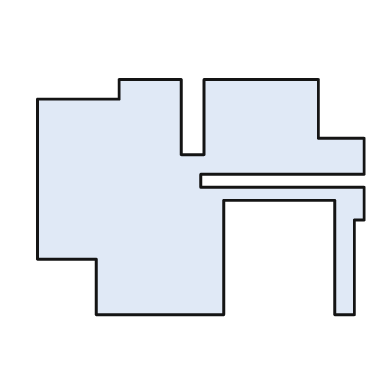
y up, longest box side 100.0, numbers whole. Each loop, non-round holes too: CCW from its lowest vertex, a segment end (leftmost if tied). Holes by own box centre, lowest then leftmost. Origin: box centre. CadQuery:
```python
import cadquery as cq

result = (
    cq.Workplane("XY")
    .moveTo(-32.0, -36.0)
    .lineTo(7.0, -36.0)
    .lineTo(7.0, -1.0)
    .lineTo(41.0, -1.0)
    .lineTo(41.0, -36.0)
    .lineTo(47.0, -36.0)
    .lineTo(47.0, -7.0)
    .lineTo(50.0, -7.0)
    .lineTo(50.0, 3.0)
    .lineTo(0.0, 3.0)
    .lineTo(0.0, 7.0)
    .lineTo(50.0, 7.0)
    .lineTo(50.0, 18.0)
    .lineTo(36.0, 18.0)
    .lineTo(36.0, 36.0)
    .lineTo(1.0, 36.0)
    .lineTo(1.0, 13.0)
    .lineTo(-6.0, 13.0)
    .lineTo(-6.0, 36.0)
    .lineTo(-25.0, 36.0)
    .lineTo(-25.0, 30.0)
    .lineTo(-50.0, 30.0)
    .lineTo(-50.0, -19.0)
    .lineTo(-32.0, -19.0)
    .close()
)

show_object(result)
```